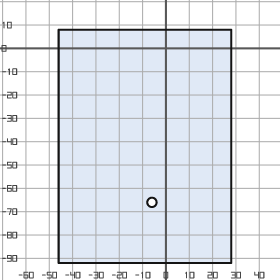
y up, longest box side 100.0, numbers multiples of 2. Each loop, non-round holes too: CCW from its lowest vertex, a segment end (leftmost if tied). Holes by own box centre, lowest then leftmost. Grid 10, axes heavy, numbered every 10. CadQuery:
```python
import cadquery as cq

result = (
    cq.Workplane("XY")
    .moveTo(-46.0, -92.0)
    .lineTo(28.0, -92.0)
    .lineTo(28.0, 8.0)
    .lineTo(-46.0, 8.0)
    .close()
    .moveTo(-6.0, -66.0)
    .circle(2.0)
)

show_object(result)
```